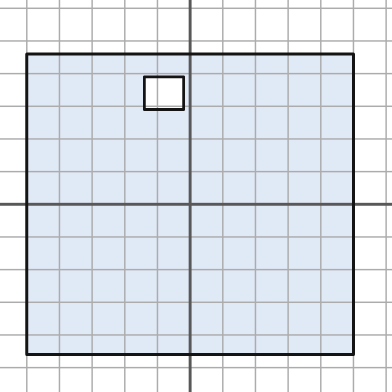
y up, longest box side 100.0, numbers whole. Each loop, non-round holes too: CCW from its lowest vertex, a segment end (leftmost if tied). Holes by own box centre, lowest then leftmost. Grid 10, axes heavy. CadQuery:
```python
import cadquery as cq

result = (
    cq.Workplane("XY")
    .moveTo(-50.0, -46.0)
    .lineTo(50.0, -46.0)
    .lineTo(50.0, 46.0)
    .lineTo(-50.0, 46.0)
    .close()
    .moveTo(-14.0, 29.0)
    .lineTo(-2.0, 29.0)
    .lineTo(-2.0, 39.0)
    .lineTo(-14.0, 39.0)
    .close()
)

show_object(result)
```